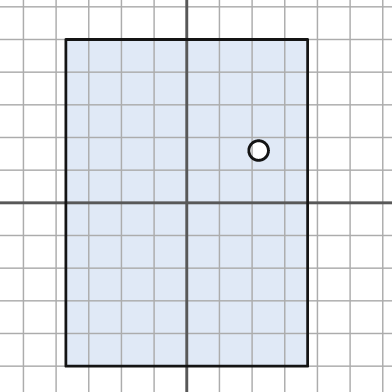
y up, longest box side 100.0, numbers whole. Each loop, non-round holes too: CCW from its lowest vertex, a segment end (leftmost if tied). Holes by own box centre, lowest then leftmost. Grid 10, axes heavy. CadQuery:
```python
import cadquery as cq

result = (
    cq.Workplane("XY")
    .moveTo(-37.0, -50.0)
    .lineTo(37.0, -50.0)
    .lineTo(37.0, 50.0)
    .lineTo(-37.0, 50.0)
    .close()
    .moveTo(22.0, 16.0)
    .circle(3.0)
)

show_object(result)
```